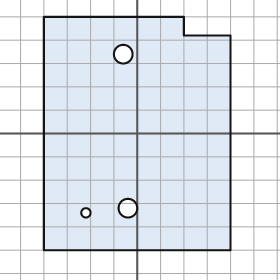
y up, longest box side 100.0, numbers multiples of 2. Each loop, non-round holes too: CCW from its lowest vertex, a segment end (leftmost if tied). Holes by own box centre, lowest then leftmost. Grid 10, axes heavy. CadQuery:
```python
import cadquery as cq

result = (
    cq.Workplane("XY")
    .moveTo(-40.0, -50.0)
    .lineTo(40.0, -50.0)
    .lineTo(40.0, 42.0)
    .lineTo(20.0, 42.0)
    .lineTo(20.0, 50.0)
    .lineTo(-40.0, 50.0)
    .close()
    .moveTo(-22.0, -34.0)
    .circle(2.0)
    .moveTo(-4.0, -32.0)
    .circle(4.0)
    .moveTo(-6.0, 34.0)
    .circle(4.0)
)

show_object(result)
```